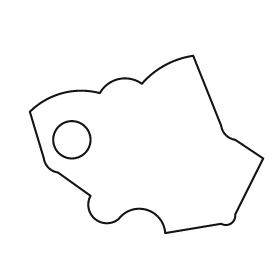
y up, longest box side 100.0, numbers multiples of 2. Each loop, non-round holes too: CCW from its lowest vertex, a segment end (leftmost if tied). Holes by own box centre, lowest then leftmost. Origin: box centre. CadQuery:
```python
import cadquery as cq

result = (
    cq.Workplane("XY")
    .moveTo(8.0, -38.0)
    .lineTo(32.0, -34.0)
    .threePointArc((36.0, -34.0), (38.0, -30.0))
    .lineTo(50.0, -6.0)
    .lineTo(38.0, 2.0)
    .threePointArc((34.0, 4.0), (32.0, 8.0))
    .lineTo(20.0, 38.0)
    .threePointArc((8.0, 34.0), (-2.0, 26.0))
    .threePointArc((-12.0, 28.0), (-20.0, 22.0))
    .threePointArc((-36.0, 22.0), (-50.0, 14.0))
    .lineTo(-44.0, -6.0)
    .threePointArc((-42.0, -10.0), (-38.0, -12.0))
    .lineTo(-24.0, -22.0)
    .threePointArc((-22.0, -32.0), (-12.0, -32.0))
    .threePointArc((0.0, -28.0), (8.0, -38.0))
    .close()
    .moveTo(-32.0, 2.0)
    .circle(8.0)
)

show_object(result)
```